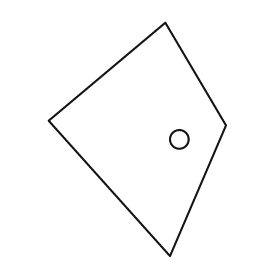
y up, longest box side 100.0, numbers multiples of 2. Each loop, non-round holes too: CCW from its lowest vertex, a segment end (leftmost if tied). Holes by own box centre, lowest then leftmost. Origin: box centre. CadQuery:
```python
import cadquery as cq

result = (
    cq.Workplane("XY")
    .moveTo(14.0, -50.0)
    .lineTo(38.0, 6.0)
    .lineTo(12.0, 50.0)
    .lineTo(-38.0, 8.0)
    .close()
    .moveTo(18.0, 0.0)
    .circle(4.0)
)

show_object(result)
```